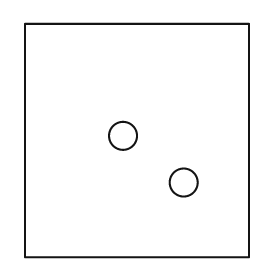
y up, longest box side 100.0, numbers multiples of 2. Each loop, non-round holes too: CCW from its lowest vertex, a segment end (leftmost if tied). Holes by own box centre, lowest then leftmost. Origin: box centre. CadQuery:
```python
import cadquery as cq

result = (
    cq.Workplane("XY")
    .moveTo(-48.0, -50.0)
    .lineTo(48.0, -50.0)
    .lineTo(48.0, 50.0)
    .lineTo(-48.0, 50.0)
    .close()
    .moveTo(20.0, -18.0)
    .circle(6.0)
    .moveTo(-6.0, 2.0)
    .circle(6.0)
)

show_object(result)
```